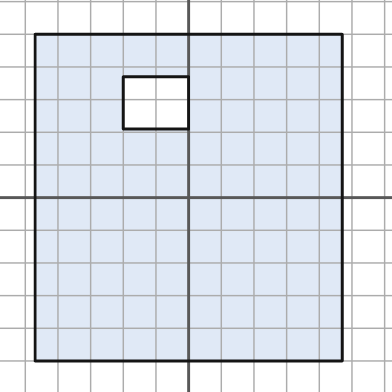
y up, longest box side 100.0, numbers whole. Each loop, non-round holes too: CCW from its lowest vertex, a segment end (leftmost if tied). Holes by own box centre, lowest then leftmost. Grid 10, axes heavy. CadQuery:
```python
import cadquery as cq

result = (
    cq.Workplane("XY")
    .moveTo(-47.0, -50.0)
    .lineTo(47.0, -50.0)
    .lineTo(47.0, 50.0)
    .lineTo(-47.0, 50.0)
    .close()
    .moveTo(-20.0, 21.0)
    .lineTo(0.0, 21.0)
    .lineTo(0.0, 37.0)
    .lineTo(-20.0, 37.0)
    .close()
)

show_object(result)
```